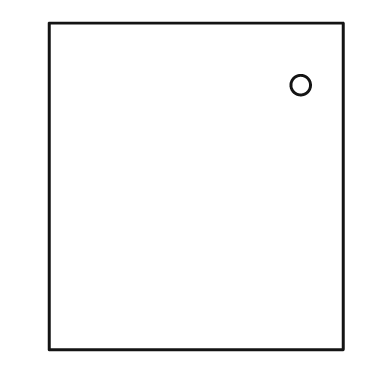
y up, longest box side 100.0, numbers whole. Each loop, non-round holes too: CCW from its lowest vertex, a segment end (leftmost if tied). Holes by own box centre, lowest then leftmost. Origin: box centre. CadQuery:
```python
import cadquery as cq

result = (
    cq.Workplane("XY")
    .moveTo(-45.0, -50.0)
    .lineTo(45.0, -50.0)
    .lineTo(45.0, 50.0)
    .lineTo(-45.0, 50.0)
    .close()
    .moveTo(32.0, 31.0)
    .circle(3.0)
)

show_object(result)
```